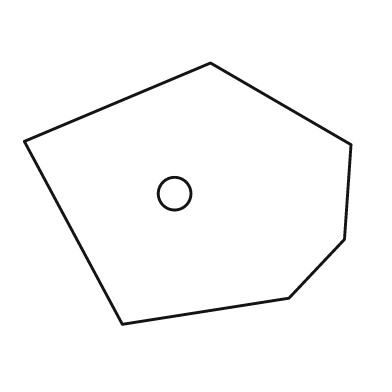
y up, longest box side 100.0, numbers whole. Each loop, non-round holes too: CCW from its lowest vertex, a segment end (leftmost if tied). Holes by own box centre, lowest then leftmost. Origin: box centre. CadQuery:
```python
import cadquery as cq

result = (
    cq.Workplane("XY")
    .moveTo(-20.0, -40.0)
    .lineTo(31.0, -32.0)
    .lineTo(48.0, -14.0)
    .lineTo(50.0, 15.0)
    .lineTo(7.0, 40.0)
    .lineTo(-50.0, 16.0)
    .close()
    .moveTo(-4.0, 0.0)
    .circle(5.0)
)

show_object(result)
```